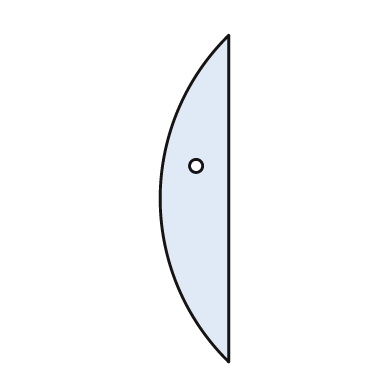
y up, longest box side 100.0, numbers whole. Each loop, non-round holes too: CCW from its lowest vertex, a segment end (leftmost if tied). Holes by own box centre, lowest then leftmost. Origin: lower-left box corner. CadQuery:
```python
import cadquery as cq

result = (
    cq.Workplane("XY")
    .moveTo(21.0, 0.0)
    .lineTo(21.0, 100.0)
    .threePointArc((0.0, 50.0), (21.0, 0.0))
    .close()
    .moveTo(11.0, 60.0)
    .circle(2.0)
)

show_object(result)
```